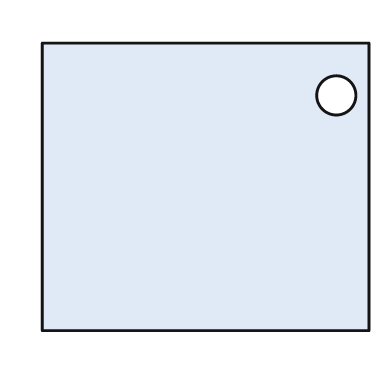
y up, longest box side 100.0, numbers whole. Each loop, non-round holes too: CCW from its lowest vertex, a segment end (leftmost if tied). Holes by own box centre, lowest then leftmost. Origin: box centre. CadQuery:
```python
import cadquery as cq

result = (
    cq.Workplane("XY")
    .moveTo(-50.0, -44.0)
    .lineTo(50.0, -44.0)
    .lineTo(50.0, 44.0)
    .lineTo(-50.0, 44.0)
    .close()
    .moveTo(40.0, 28.0)
    .circle(6.0)
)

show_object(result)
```